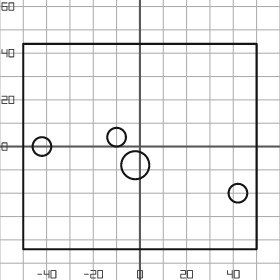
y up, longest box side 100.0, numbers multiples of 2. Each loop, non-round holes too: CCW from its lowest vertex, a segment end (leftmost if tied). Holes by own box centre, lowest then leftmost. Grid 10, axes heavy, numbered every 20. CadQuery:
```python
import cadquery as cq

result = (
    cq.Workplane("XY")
    .moveTo(-50.0, -44.0)
    .lineTo(50.0, -44.0)
    .lineTo(50.0, 44.0)
    .lineTo(-50.0, 44.0)
    .close()
    .moveTo(42.0, -20.0)
    .circle(4.0)
    .moveTo(-2.0, -8.0)
    .circle(6.0)
    .moveTo(-42.0, 0.0)
    .circle(4.0)
    .moveTo(-10.0, 4.0)
    .circle(4.0)
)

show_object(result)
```